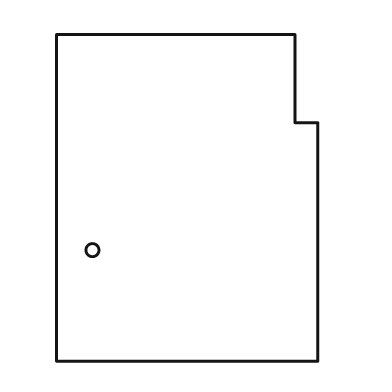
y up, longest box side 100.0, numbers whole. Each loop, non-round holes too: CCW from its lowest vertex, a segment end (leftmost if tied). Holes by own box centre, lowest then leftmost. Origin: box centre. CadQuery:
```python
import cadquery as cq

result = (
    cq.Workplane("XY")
    .moveTo(-40.0, -50.0)
    .lineTo(40.0, -50.0)
    .lineTo(40.0, 23.0)
    .lineTo(33.0, 23.0)
    .lineTo(33.0, 50.0)
    .lineTo(-40.0, 50.0)
    .close()
    .moveTo(-29.0, -16.0)
    .circle(2.0)
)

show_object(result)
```